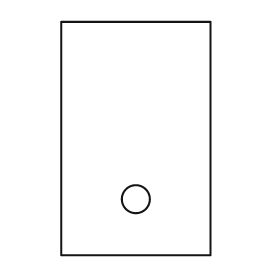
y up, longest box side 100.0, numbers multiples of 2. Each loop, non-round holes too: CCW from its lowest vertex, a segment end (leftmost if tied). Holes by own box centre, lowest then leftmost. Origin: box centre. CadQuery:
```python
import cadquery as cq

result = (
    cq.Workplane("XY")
    .moveTo(-32.0, -50.0)
    .lineTo(32.0, -50.0)
    .lineTo(32.0, 50.0)
    .lineTo(-32.0, 50.0)
    .close()
    .moveTo(0.0, -26.0)
    .circle(6.0)
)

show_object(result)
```